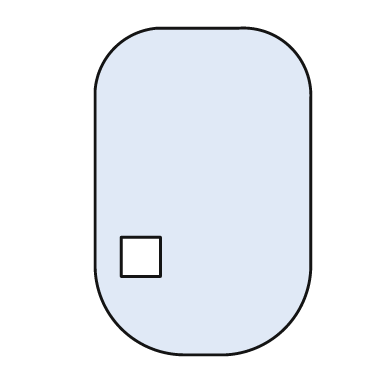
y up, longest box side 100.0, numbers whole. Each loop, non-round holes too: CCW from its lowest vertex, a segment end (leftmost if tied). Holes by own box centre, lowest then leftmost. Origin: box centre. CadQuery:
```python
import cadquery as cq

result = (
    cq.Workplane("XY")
    .moveTo(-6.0, -50.0)
    .lineTo(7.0, -50.0)
    .threePointArc((25.0, -42.0), (33.0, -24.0))
    .lineTo(33.0, 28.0)
    .threePointArc((27.0, 44.0), (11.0, 50.0))
    .lineTo(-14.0, 50.0)
    .threePointArc((-27.0, 44.0), (-33.0, 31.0))
    .lineTo(-33.0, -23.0)
    .threePointArc((-25.0, -42.0), (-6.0, -50.0))
    .close()
    .moveTo(-25.0, -26.0)
    .lineTo(-13.0, -26.0)
    .lineTo(-13.0, -14.0)
    .lineTo(-25.0, -14.0)
    .close()
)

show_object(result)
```